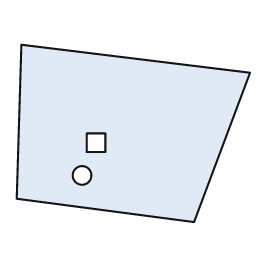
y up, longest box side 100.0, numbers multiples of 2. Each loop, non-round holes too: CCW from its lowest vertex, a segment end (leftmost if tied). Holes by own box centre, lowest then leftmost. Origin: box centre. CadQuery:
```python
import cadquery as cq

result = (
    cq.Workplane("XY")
    .moveTo(26.0, -38.0)
    .lineTo(50.0, 26.0)
    .lineTo(-48.0, 38.0)
    .lineTo(-50.0, -28.0)
    .close()
    .moveTo(-22.0, -18.0)
    .circle(4.0)
    .moveTo(-20.0, -8.0)
    .lineTo(-12.0, -8.0)
    .lineTo(-12.0, 0.0)
    .lineTo(-20.0, 0.0)
    .close()
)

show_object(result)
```